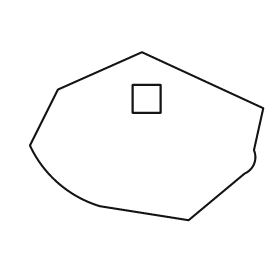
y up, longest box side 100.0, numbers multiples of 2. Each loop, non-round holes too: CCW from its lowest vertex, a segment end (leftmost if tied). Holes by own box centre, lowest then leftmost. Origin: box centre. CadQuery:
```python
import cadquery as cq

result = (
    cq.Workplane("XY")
    .moveTo(18.0, -36.0)
    .lineTo(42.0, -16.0)
    .threePointArc((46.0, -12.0), (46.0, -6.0))
    .lineTo(50.0, 12.0)
    .lineTo(-2.0, 36.0)
    .lineTo(-38.0, 20.0)
    .lineTo(-50.0, -4.0)
    .threePointArc((-38.0, -20.0), (-20.0, -30.0))
    .close()
    .moveTo(-6.0, 10.0)
    .lineTo(6.0, 10.0)
    .lineTo(6.0, 22.0)
    .lineTo(-6.0, 22.0)
    .close()
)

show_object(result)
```